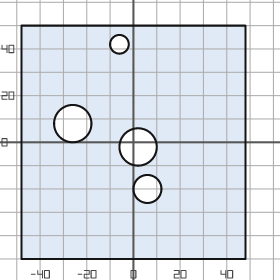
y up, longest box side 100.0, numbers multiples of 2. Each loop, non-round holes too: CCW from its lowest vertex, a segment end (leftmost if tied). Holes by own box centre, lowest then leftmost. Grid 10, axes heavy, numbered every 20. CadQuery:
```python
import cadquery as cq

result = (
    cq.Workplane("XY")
    .moveTo(-48.0, -50.0)
    .lineTo(48.0, -50.0)
    .lineTo(48.0, 50.0)
    .lineTo(-48.0, 50.0)
    .close()
    .moveTo(6.0, -20.0)
    .circle(6.0)
    .moveTo(2.0, -2.0)
    .circle(8.0)
    .moveTo(-26.0, 8.0)
    .circle(8.0)
    .moveTo(-6.0, 42.0)
    .circle(4.0)
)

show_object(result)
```